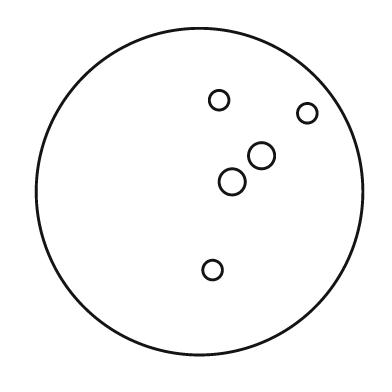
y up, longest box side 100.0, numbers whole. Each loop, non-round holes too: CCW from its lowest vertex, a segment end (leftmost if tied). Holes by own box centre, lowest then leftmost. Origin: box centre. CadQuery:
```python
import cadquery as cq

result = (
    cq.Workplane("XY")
    .moveTo(0.0, 0.0)
    .circle(50.0)
    .moveTo(4.0, -24.0)
    .circle(3.0)
    .moveTo(10.0, 3.0)
    .circle(4.0)
    .moveTo(19.0, 11.0)
    .circle(4.0)
    .moveTo(33.0, 24.0)
    .circle(3.0)
    .moveTo(6.0, 28.0)
    .circle(3.0)
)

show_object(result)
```